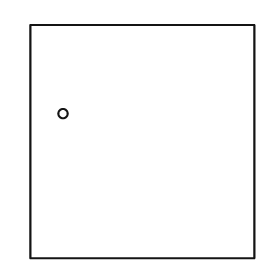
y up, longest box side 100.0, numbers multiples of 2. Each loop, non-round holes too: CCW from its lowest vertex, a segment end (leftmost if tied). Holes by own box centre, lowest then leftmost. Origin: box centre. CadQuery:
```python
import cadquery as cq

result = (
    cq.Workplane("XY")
    .moveTo(-48.0, -50.0)
    .lineTo(48.0, -50.0)
    .lineTo(48.0, 50.0)
    .lineTo(-48.0, 50.0)
    .close()
    .moveTo(-34.0, 12.0)
    .circle(2.0)
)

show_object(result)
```